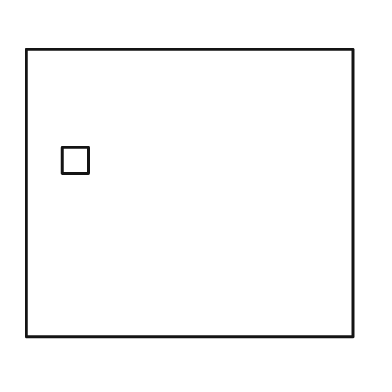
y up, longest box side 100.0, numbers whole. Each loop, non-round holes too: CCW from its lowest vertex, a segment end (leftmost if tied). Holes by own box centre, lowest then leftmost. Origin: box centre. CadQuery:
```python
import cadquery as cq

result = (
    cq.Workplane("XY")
    .moveTo(-50.0, -44.0)
    .lineTo(50.0, -44.0)
    .lineTo(50.0, 44.0)
    .lineTo(-50.0, 44.0)
    .close()
    .moveTo(-39.0, 6.0)
    .lineTo(-31.0, 6.0)
    .lineTo(-31.0, 14.0)
    .lineTo(-39.0, 14.0)
    .close()
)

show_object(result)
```